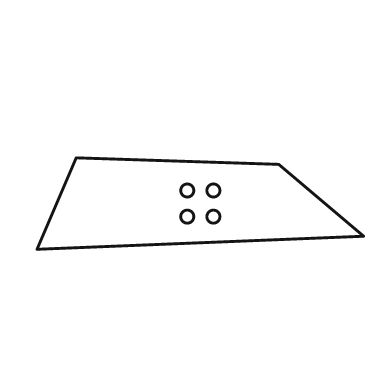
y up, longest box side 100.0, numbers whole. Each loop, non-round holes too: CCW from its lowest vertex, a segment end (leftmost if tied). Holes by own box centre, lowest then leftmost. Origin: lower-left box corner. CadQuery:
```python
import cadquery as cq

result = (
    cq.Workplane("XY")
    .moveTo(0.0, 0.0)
    .lineTo(100.0, 4.0)
    .lineTo(74.0, 26.0)
    .lineTo(12.0, 28.0)
    .close()
    .moveTo(46.0, 10.0)
    .circle(2.0)
    .moveTo(54.0, 10.0)
    .circle(2.0)
    .moveTo(46.0, 18.0)
    .circle(2.0)
    .moveTo(54.0, 18.0)
    .circle(2.0)
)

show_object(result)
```